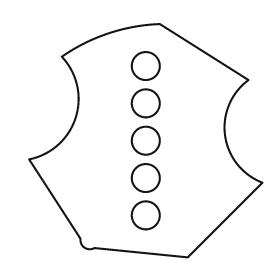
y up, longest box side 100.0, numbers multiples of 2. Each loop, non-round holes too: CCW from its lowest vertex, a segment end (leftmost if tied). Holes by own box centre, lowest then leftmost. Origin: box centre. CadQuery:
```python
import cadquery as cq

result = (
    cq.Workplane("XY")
    .moveTo(18.0, -50.0)
    .lineTo(50.0, -18.0)
    .threePointArc((34.0, 2.0), (44.0, 26.0))
    .lineTo(6.0, 50.0)
    .threePointArc((-16.0, 46.0), (-36.0, 36.0))
    .threePointArc((-30.0, 10.0), (-50.0, -8.0))
    .lineTo(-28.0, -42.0)
    .threePointArc((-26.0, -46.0), (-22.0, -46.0))
    .close()
    .moveTo(0.0, -32.0)
    .circle(6.0)
    .moveTo(0.0, -16.0)
    .circle(6.0)
    .moveTo(0.0, 0.0)
    .circle(6.0)
    .moveTo(0.0, 16.0)
    .circle(6.0)
    .moveTo(0.0, 32.0)
    .circle(6.0)
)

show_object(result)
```